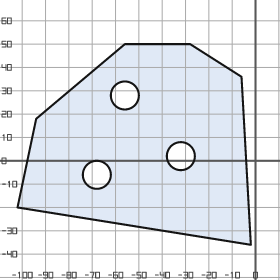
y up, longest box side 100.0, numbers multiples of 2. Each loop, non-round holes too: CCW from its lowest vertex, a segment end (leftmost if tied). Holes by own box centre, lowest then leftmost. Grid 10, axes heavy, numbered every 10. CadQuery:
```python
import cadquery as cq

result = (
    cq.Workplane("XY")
    .moveTo(-2.0, -36.0)
    .lineTo(-6.0, 36.0)
    .lineTo(-28.0, 50.0)
    .lineTo(-56.0, 50.0)
    .lineTo(-94.0, 18.0)
    .lineTo(-102.0, -20.0)
    .close()
    .moveTo(-68.0, -6.0)
    .circle(6.0)
    .moveTo(-32.0, 2.0)
    .circle(6.0)
    .moveTo(-56.0, 28.0)
    .circle(6.0)
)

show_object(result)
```